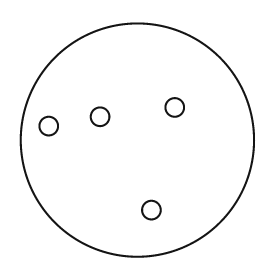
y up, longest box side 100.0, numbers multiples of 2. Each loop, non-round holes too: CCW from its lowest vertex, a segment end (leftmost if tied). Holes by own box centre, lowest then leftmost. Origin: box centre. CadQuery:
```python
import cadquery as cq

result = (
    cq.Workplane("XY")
    .moveTo(0.0, 0.0)
    .circle(50.0)
    .moveTo(6.0, -30.0)
    .circle(4.0)
    .moveTo(-38.0, 6.0)
    .circle(4.0)
    .moveTo(-16.0, 10.0)
    .circle(4.0)
    .moveTo(16.0, 14.0)
    .circle(4.0)
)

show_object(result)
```